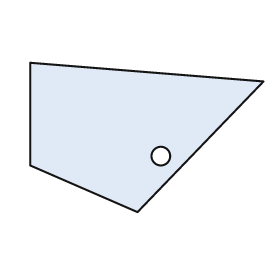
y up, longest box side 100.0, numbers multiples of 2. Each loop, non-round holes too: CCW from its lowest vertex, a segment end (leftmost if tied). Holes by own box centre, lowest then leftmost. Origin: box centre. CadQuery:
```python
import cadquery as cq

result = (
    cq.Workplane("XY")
    .moveTo(-4.0, -32.0)
    .lineTo(50.0, 24.0)
    .lineTo(-50.0, 32.0)
    .lineTo(-50.0, -12.0)
    .close()
    .moveTo(6.0, -8.0)
    .circle(4.0)
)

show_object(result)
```